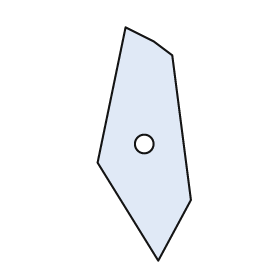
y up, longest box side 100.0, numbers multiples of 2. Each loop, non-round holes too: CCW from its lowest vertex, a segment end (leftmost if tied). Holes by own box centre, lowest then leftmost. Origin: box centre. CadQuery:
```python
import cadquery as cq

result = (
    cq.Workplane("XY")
    .moveTo(6.0, -50.0)
    .lineTo(20.0, -24.0)
    .lineTo(12.0, 38.0)
    .lineTo(4.0, 44.0)
    .lineTo(-8.0, 50.0)
    .lineTo(-20.0, -8.0)
    .close()
    .moveTo(0.0, 0.0)
    .circle(4.0)
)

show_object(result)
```